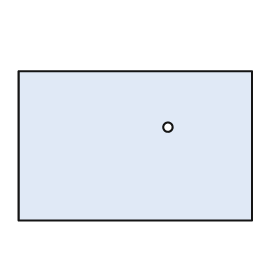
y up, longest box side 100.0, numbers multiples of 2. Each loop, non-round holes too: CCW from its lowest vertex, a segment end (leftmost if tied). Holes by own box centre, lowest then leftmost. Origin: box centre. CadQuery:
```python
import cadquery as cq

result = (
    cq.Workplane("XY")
    .moveTo(-50.0, -32.0)
    .lineTo(50.0, -32.0)
    .lineTo(50.0, 32.0)
    .lineTo(-50.0, 32.0)
    .close()
    .moveTo(14.0, 8.0)
    .circle(2.0)
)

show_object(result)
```